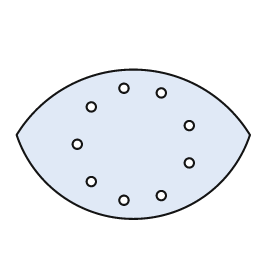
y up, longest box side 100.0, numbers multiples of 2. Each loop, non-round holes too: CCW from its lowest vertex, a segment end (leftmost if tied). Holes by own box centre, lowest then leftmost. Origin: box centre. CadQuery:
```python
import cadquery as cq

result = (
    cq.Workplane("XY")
    .moveTo(-50.0, 4.0)
    .threePointArc((0.0, -32.0), (50.0, 4.0))
    .threePointArc((0.0, 32.0), (-50.0, 4.0))
    .close()
    .moveTo(-4.0, -24.0)
    .circle(2.0)
    .moveTo(12.0, -22.0)
    .circle(2.0)
    .moveTo(-18.0, -16.0)
    .circle(2.0)
    .moveTo(24.0, -8.0)
    .circle(2.0)
    .moveTo(-24.0, 0.0)
    .circle(2.0)
    .moveTo(24.0, 8.0)
    .circle(2.0)
    .moveTo(-18.0, 16.0)
    .circle(2.0)
    .moveTo(12.0, 22.0)
    .circle(2.0)
    .moveTo(-4.0, 24.0)
    .circle(2.0)
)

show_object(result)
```